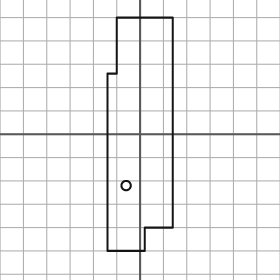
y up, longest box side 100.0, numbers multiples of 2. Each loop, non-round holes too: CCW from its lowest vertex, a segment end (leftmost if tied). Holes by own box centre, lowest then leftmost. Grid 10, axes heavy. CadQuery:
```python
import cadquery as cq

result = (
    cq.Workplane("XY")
    .moveTo(-14.0, -50.0)
    .lineTo(2.0, -50.0)
    .lineTo(2.0, -40.0)
    .lineTo(14.0, -40.0)
    .lineTo(14.0, 50.0)
    .lineTo(-10.0, 50.0)
    .lineTo(-10.0, 26.0)
    .lineTo(-14.0, 26.0)
    .close()
    .moveTo(-6.0, -22.0)
    .circle(2.0)
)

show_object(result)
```